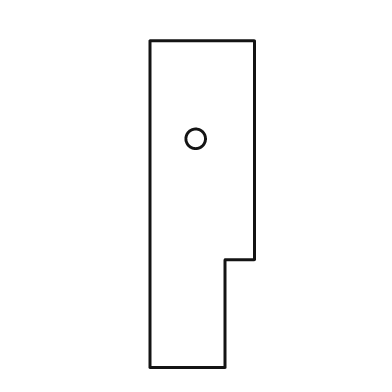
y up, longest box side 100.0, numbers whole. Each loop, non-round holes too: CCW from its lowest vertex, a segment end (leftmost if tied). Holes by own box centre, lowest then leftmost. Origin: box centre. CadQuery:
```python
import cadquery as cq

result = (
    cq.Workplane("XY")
    .moveTo(-16.0, -50.0)
    .lineTo(7.0, -50.0)
    .lineTo(7.0, -17.0)
    .lineTo(16.0, -17.0)
    .lineTo(16.0, 50.0)
    .lineTo(-16.0, 50.0)
    .close()
    .moveTo(-2.0, 20.0)
    .circle(3.0)
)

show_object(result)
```